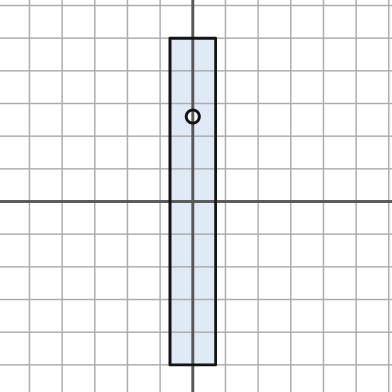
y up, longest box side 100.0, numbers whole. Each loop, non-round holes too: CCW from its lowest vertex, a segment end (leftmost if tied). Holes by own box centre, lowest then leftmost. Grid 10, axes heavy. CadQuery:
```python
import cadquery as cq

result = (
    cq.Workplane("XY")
    .moveTo(-7.0, -50.0)
    .lineTo(7.0, -50.0)
    .lineTo(7.0, 50.0)
    .lineTo(-7.0, 50.0)
    .close()
    .moveTo(0.0, 26.0)
    .circle(2.0)
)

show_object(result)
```